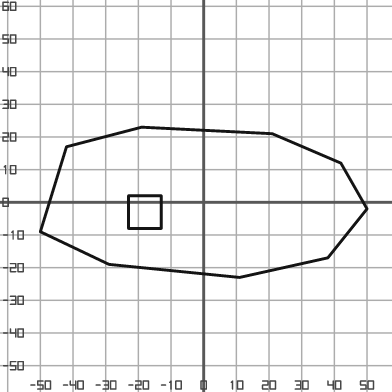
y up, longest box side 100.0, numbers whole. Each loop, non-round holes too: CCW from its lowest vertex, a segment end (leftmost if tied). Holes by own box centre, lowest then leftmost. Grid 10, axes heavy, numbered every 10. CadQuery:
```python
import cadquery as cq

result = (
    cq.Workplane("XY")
    .moveTo(11.0, -23.0)
    .lineTo(38.0, -17.0)
    .lineTo(50.0, -2.0)
    .lineTo(42.0, 12.0)
    .lineTo(21.0, 21.0)
    .lineTo(-19.0, 23.0)
    .lineTo(-42.0, 17.0)
    .lineTo(-50.0, -9.0)
    .lineTo(-29.0, -19.0)
    .close()
    .moveTo(-23.0, -8.0)
    .lineTo(-13.0, -8.0)
    .lineTo(-13.0, 2.0)
    .lineTo(-23.0, 2.0)
    .close()
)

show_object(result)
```